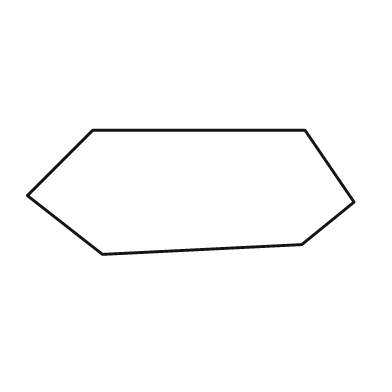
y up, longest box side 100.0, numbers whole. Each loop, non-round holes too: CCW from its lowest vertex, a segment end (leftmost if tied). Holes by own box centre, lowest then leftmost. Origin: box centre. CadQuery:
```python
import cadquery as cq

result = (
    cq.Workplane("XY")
    .moveTo(-27.0, -19.0)
    .lineTo(34.0, -16.0)
    .lineTo(50.0, -3.0)
    .lineTo(35.0, 19.0)
    .lineTo(-30.0, 19.0)
    .lineTo(-50.0, -1.0)
    .close()
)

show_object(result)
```